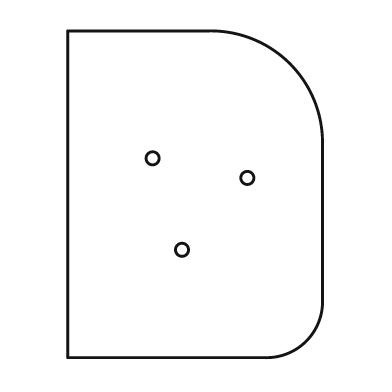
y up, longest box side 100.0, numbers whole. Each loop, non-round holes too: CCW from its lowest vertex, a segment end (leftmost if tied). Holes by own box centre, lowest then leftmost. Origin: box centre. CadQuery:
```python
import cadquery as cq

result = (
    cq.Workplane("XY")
    .moveTo(-39.0, -50.0)
    .lineTo(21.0, -50.0)
    .threePointArc((34.0, -45.0), (39.0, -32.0))
    .lineTo(39.0, 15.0)
    .threePointArc((29.0, 40.0), (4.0, 50.0))
    .lineTo(-39.0, 50.0)
    .close()
    .moveTo(-4.0, -17.0)
    .circle(2.0)
    .moveTo(16.0, 5.0)
    .circle(2.0)
    .moveTo(-13.0, 11.0)
    .circle(2.0)
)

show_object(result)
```